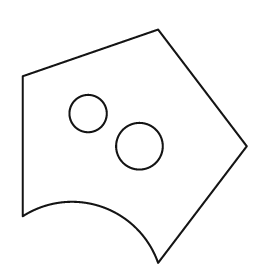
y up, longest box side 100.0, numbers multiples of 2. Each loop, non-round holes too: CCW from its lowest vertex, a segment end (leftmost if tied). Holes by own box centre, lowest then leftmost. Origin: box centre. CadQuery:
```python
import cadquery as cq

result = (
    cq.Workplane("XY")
    .moveTo(10.0, -50.0)
    .lineTo(48.0, 0.0)
    .lineTo(10.0, 50.0)
    .lineTo(-48.0, 30.0)
    .lineTo(-48.0, -30.0)
    .threePointArc((-14.0, -26.0), (10.0, -50.0))
    .close()
    .moveTo(2.0, 0.0)
    .circle(10.0)
    .moveTo(-20.0, 14.0)
    .circle(8.0)
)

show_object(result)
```